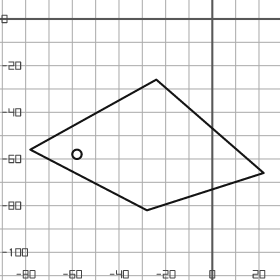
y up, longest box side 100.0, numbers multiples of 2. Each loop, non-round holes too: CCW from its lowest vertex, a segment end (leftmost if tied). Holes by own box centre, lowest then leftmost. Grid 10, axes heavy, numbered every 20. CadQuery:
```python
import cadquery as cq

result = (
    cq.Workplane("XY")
    .moveTo(-28.0, -82.0)
    .lineTo(22.0, -66.0)
    .lineTo(-24.0, -26.0)
    .lineTo(-78.0, -56.0)
    .close()
    .moveTo(-58.0, -58.0)
    .circle(2.0)
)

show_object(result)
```